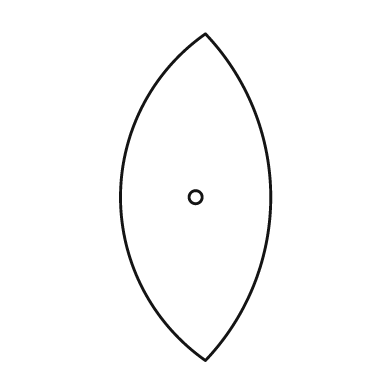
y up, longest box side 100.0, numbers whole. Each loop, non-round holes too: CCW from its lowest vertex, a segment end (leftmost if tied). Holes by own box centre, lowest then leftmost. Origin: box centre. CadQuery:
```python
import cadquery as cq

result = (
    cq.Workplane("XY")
    .moveTo(3.0, -50.0)
    .threePointArc((23.0, 0.0), (3.0, 50.0))
    .threePointArc((-23.0, 0.0), (3.0, -50.0))
    .close()
    .moveTo(0.0, 0.0)
    .circle(2.0)
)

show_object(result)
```